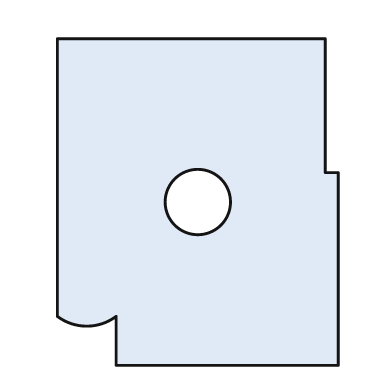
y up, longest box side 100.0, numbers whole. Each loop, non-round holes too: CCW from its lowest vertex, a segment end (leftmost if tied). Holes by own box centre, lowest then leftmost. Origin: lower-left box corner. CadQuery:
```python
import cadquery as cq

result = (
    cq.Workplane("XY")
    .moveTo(18.0, 0.0)
    .lineTo(86.0, 0.0)
    .lineTo(86.0, 59.0)
    .lineTo(82.0, 59.0)
    .lineTo(82.0, 100.0)
    .lineTo(0.0, 100.0)
    .lineTo(0.0, 15.0)
    .threePointArc((9.0, 12.0), (18.0, 15.0))
    .close()
    .moveTo(43.0, 50.0)
    .circle(10.0)
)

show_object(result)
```